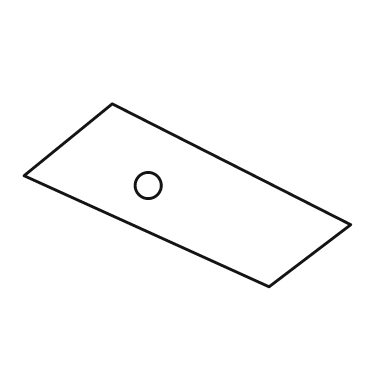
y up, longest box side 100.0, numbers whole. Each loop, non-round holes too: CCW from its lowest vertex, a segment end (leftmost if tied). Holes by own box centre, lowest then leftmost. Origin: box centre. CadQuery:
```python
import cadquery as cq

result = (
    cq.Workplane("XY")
    .moveTo(25.0, -28.0)
    .lineTo(50.0, -9.0)
    .lineTo(-23.0, 28.0)
    .lineTo(-50.0, 6.0)
    .close()
    .moveTo(-12.0, 3.0)
    .circle(4.0)
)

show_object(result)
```